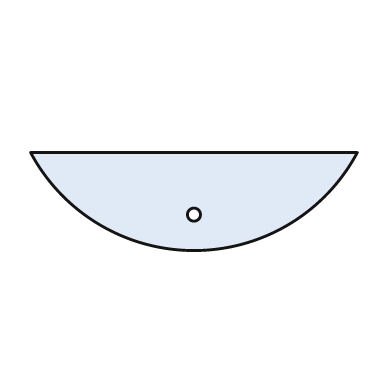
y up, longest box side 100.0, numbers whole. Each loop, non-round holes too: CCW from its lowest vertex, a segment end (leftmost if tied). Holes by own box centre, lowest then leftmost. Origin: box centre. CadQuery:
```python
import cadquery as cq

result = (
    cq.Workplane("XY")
    .moveTo(-50.0, 15.0)
    .threePointArc((0.0, -15.0), (50.0, 15.0))
    .close()
    .moveTo(0.0, -4.0)
    .circle(2.0)
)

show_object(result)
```